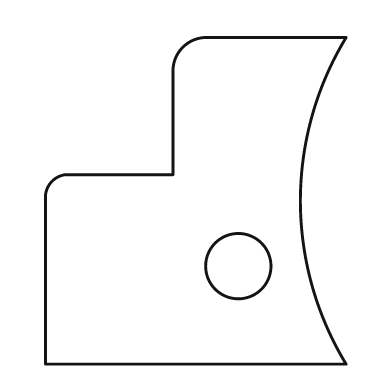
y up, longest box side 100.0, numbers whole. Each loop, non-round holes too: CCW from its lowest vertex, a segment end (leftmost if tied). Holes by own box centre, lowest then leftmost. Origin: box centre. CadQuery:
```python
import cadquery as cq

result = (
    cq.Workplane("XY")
    .moveTo(-46.0, -50.0)
    .lineTo(46.0, -50.0)
    .threePointArc((32.0, 0.0), (46.0, 50.0))
    .lineTo(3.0, 50.0)
    .threePointArc((-4.0, 47.0), (-7.0, 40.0))
    .lineTo(-7.0, 8.0)
    .lineTo(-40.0, 8.0)
    .threePointArc((-44.0, 6.0), (-46.0, 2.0))
    .close()
    .moveTo(13.0, -20.0)
    .circle(10.0)
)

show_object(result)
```